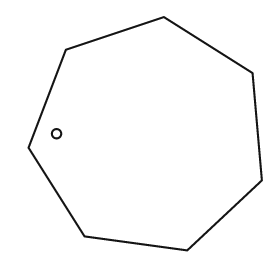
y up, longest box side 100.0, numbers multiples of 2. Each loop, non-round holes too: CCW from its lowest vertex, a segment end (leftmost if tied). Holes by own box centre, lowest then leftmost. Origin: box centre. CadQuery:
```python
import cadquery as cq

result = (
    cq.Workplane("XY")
    .moveTo(18.0, -50.0)
    .lineTo(50.0, -20.0)
    .lineTo(46.0, 26.0)
    .lineTo(8.0, 50.0)
    .lineTo(-34.0, 36.0)
    .lineTo(-50.0, -6.0)
    .lineTo(-26.0, -44.0)
    .close()
    .moveTo(-38.0, 0.0)
    .circle(2.0)
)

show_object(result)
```